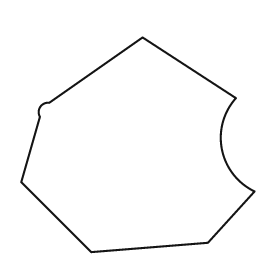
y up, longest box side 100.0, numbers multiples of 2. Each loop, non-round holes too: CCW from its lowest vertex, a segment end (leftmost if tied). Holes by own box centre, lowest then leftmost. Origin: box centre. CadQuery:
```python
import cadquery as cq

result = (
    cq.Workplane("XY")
    .moveTo(-20.0, -46.0)
    .lineTo(30.0, -42.0)
    .lineTo(50.0, -20.0)
    .threePointArc((36.0, -2.0), (42.0, 20.0))
    .lineTo(2.0, 46.0)
    .lineTo(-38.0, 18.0)
    .threePointArc((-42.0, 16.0), (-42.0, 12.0))
    .lineTo(-50.0, -16.0)
    .close()
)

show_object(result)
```